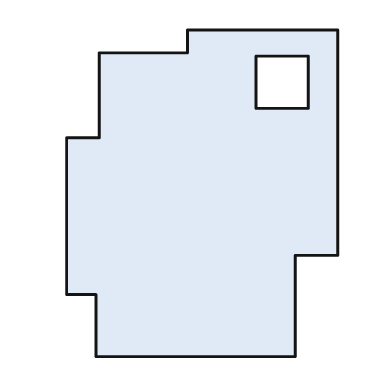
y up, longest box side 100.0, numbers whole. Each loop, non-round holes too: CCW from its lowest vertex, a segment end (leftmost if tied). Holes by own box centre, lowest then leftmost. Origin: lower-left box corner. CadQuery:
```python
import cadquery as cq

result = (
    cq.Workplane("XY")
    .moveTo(9.0, 0.0)
    .lineTo(70.0, 0.0)
    .lineTo(70.0, 31.0)
    .lineTo(83.0, 31.0)
    .lineTo(83.0, 100.0)
    .lineTo(37.0, 100.0)
    .lineTo(37.0, 93.0)
    .lineTo(10.0, 93.0)
    .lineTo(10.0, 67.0)
    .lineTo(0.0, 67.0)
    .lineTo(0.0, 19.0)
    .lineTo(9.0, 19.0)
    .close()
    .moveTo(58.0, 76.0)
    .lineTo(74.0, 76.0)
    .lineTo(74.0, 92.0)
    .lineTo(58.0, 92.0)
    .close()
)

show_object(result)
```